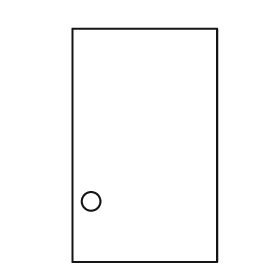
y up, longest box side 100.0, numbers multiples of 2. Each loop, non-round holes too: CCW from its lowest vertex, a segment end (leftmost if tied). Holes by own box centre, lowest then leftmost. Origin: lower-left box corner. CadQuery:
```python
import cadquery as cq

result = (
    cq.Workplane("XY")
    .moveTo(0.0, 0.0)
    .lineTo(62.0, 0.0)
    .lineTo(62.0, 100.0)
    .lineTo(0.0, 100.0)
    .close()
    .moveTo(8.0, 26.0)
    .circle(4.0)
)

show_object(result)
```